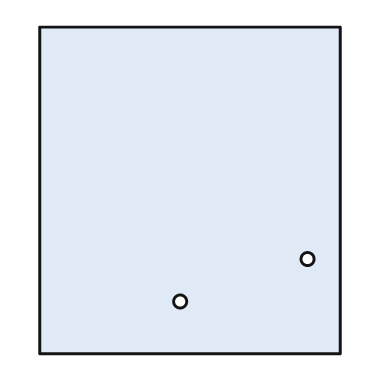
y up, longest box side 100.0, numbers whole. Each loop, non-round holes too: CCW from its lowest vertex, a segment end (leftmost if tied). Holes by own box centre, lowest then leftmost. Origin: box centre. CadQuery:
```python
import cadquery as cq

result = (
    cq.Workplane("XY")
    .moveTo(-46.0, -50.0)
    .lineTo(46.0, -50.0)
    .lineTo(46.0, 50.0)
    .lineTo(-46.0, 50.0)
    .close()
    .moveTo(-3.0, -34.0)
    .circle(2.0)
    .moveTo(36.0, -21.0)
    .circle(2.0)
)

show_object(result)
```